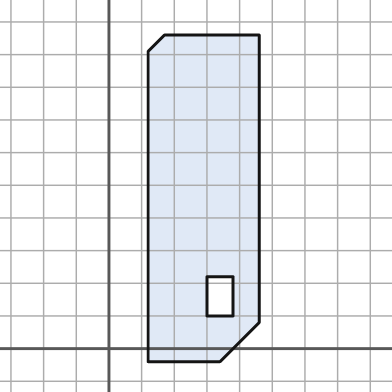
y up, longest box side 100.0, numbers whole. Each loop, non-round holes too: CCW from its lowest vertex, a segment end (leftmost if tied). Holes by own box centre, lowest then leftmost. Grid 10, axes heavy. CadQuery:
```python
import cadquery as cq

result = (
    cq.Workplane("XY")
    .moveTo(12.0, -4.0)
    .lineTo(34.0, -4.0)
    .lineTo(46.0, 8.0)
    .lineTo(46.0, 96.0)
    .lineTo(17.0, 96.0)
    .lineTo(12.0, 91.0)
    .close()
    .moveTo(30.0, 10.0)
    .lineTo(38.0, 10.0)
    .lineTo(38.0, 22.0)
    .lineTo(30.0, 22.0)
    .close()
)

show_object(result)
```